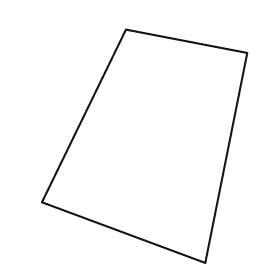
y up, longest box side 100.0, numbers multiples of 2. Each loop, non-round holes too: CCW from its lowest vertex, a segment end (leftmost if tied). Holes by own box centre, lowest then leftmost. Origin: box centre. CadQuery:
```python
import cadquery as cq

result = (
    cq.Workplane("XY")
    .moveTo(26.0, -50.0)
    .lineTo(44.0, 40.0)
    .lineTo(-8.0, 50.0)
    .lineTo(-44.0, -24.0)
    .close()
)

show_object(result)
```